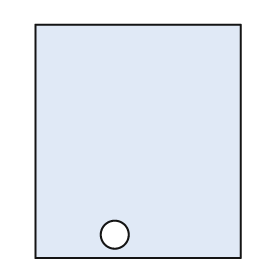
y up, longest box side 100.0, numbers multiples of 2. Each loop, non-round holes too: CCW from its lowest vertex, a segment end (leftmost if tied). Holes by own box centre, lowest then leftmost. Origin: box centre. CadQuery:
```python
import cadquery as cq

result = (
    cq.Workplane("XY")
    .moveTo(-44.0, -50.0)
    .lineTo(44.0, -50.0)
    .lineTo(44.0, 50.0)
    .lineTo(-44.0, 50.0)
    .close()
    .moveTo(-10.0, -40.0)
    .circle(6.0)
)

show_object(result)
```